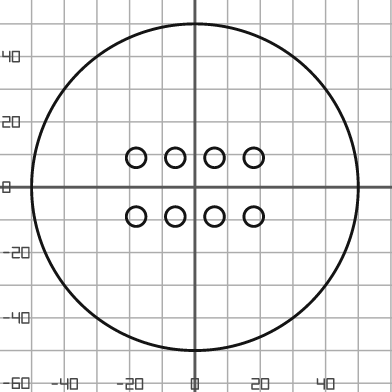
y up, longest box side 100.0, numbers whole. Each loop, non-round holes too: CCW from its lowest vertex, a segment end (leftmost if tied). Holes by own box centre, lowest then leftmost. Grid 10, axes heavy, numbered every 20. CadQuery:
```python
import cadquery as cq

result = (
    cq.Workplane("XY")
    .moveTo(0.0, 0.0)
    .circle(50.0)
    .moveTo(-18.0, -9.0)
    .circle(3.0)
    .moveTo(-6.0, -9.0)
    .circle(3.0)
    .moveTo(6.0, -9.0)
    .circle(3.0)
    .moveTo(18.0, -9.0)
    .circle(3.0)
    .moveTo(-18.0, 9.0)
    .circle(3.0)
    .moveTo(-6.0, 9.0)
    .circle(3.0)
    .moveTo(6.0, 9.0)
    .circle(3.0)
    .moveTo(18.0, 9.0)
    .circle(3.0)
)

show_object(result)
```